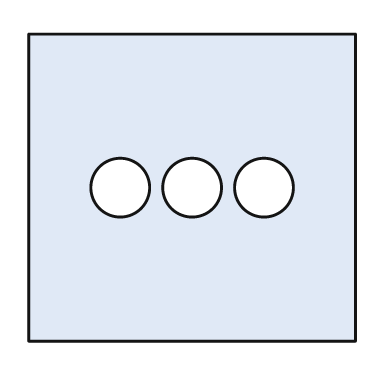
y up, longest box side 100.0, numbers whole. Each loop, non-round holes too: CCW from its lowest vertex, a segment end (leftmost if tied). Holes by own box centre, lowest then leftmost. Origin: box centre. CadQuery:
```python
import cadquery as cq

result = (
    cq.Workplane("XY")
    .moveTo(-50.0, -47.0)
    .lineTo(50.0, -47.0)
    .lineTo(50.0, 47.0)
    .lineTo(-50.0, 47.0)
    .close()
    .moveTo(-22.0, 0.0)
    .circle(9.0)
    .moveTo(0.0, 0.0)
    .circle(9.0)
    .moveTo(22.0, 0.0)
    .circle(9.0)
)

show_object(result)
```